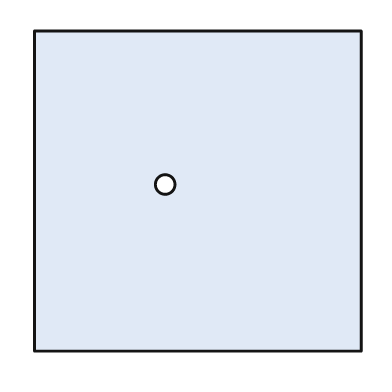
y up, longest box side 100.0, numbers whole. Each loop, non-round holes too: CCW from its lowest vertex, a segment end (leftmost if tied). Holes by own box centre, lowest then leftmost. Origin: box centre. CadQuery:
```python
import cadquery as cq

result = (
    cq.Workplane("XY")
    .moveTo(-50.0, -49.0)
    .lineTo(50.0, -49.0)
    .lineTo(50.0, 49.0)
    .lineTo(-50.0, 49.0)
    .close()
    .moveTo(-10.0, 2.0)
    .circle(3.0)
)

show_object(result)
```